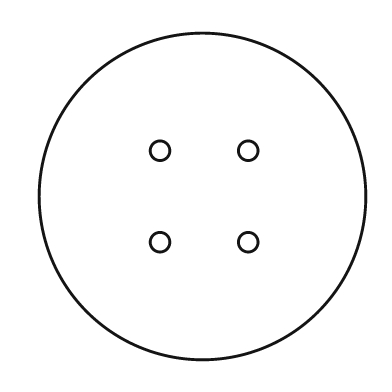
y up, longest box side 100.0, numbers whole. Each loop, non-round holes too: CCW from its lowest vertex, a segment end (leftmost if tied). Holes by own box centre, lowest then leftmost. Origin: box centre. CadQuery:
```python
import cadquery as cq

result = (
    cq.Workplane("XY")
    .moveTo(0.0, 0.0)
    .circle(50.0)
    .moveTo(-13.0, -14.0)
    .circle(3.0)
    .moveTo(14.0, -14.0)
    .circle(3.0)
    .moveTo(-13.0, 14.0)
    .circle(3.0)
    .moveTo(14.0, 14.0)
    .circle(3.0)
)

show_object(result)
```